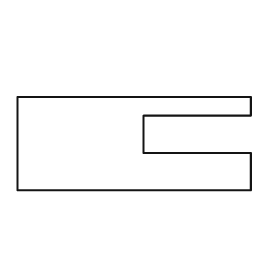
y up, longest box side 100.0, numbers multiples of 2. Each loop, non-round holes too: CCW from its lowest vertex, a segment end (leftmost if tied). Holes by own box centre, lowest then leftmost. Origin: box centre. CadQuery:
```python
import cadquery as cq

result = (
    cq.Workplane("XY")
    .moveTo(-50.0, -20.0)
    .lineTo(50.0, -20.0)
    .lineTo(50.0, -4.0)
    .lineTo(4.0, -4.0)
    .lineTo(4.0, 12.0)
    .lineTo(50.0, 12.0)
    .lineTo(50.0, 20.0)
    .lineTo(-50.0, 20.0)
    .close()
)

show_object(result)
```